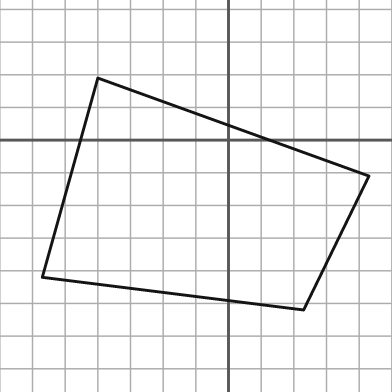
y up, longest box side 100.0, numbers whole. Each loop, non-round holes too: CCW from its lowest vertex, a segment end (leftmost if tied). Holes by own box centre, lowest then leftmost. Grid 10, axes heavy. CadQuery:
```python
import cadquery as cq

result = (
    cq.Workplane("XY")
    .moveTo(23.0, -52.0)
    .lineTo(43.0, -11.0)
    .lineTo(-40.0, 19.0)
    .lineTo(-57.0, -42.0)
    .close()
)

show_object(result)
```